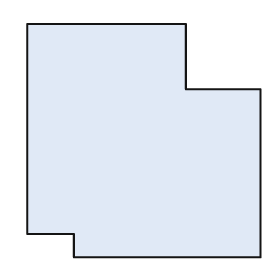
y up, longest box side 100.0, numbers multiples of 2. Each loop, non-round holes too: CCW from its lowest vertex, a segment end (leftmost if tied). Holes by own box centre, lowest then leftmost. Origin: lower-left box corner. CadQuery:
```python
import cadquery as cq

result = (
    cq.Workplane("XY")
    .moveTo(20.0, 0.0)
    .lineTo(100.0, 0.0)
    .lineTo(100.0, 72.0)
    .lineTo(68.0, 72.0)
    .lineTo(68.0, 100.0)
    .lineTo(0.0, 100.0)
    .lineTo(0.0, 10.0)
    .lineTo(20.0, 10.0)
    .close()
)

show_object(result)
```